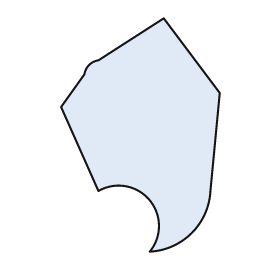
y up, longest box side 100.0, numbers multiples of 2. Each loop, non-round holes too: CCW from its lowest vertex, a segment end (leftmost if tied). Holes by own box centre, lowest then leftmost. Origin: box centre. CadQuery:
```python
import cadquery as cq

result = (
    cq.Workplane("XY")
    .moveTo(4.0, -50.0)
    .threePointArc((22.0, -42.0), (30.0, -24.0))
    .lineTo(34.0, 18.0)
    .lineTo(10.0, 50.0)
    .lineTo(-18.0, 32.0)
    .threePointArc((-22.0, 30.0), (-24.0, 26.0))
    .lineTo(-34.0, 12.0)
    .lineTo(-18.0, -24.0)
    .threePointArc((4.0, -28.0), (4.0, -50.0))
    .close()
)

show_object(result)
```